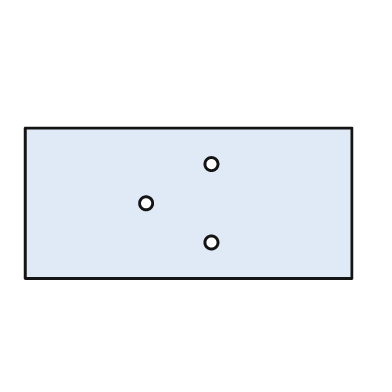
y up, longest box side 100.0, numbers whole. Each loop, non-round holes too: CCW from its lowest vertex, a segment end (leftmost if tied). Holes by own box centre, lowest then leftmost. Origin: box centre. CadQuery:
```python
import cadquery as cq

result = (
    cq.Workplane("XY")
    .moveTo(-50.0, -23.0)
    .lineTo(50.0, -23.0)
    .lineTo(50.0, 23.0)
    .lineTo(-50.0, 23.0)
    .close()
    .moveTo(7.0, -12.0)
    .circle(2.0)
    .moveTo(-13.0, 0.0)
    .circle(2.0)
    .moveTo(7.0, 12.0)
    .circle(2.0)
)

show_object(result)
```